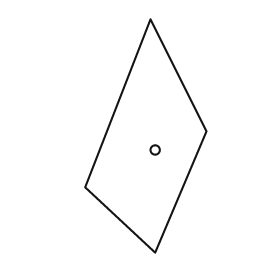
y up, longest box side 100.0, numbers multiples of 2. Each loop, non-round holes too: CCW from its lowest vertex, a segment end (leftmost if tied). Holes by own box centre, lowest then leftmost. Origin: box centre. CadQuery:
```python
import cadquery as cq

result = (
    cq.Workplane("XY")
    .moveTo(4.0, -50.0)
    .lineTo(26.0, 2.0)
    .lineTo(2.0, 50.0)
    .lineTo(-26.0, -22.0)
    .close()
    .moveTo(4.0, -6.0)
    .circle(2.0)
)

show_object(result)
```